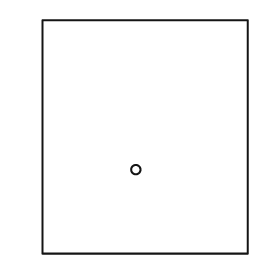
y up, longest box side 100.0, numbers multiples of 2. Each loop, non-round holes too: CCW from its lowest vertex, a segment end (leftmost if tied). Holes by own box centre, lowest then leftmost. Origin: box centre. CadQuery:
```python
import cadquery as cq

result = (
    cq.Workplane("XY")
    .moveTo(-44.0, -50.0)
    .lineTo(44.0, -50.0)
    .lineTo(44.0, 50.0)
    .lineTo(-44.0, 50.0)
    .close()
    .moveTo(-4.0, -14.0)
    .circle(2.0)
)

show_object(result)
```